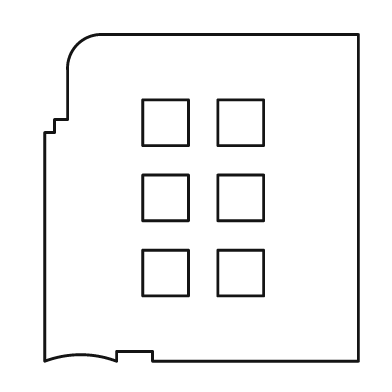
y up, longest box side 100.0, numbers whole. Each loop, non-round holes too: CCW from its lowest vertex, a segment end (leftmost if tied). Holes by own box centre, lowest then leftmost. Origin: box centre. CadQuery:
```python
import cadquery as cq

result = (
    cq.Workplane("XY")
    .moveTo(-48.0, -50.0)
    .threePointArc((-37.0, -48.0), (-26.0, -50.0))
    .lineTo(-26.0, -47.0)
    .lineTo(-15.0, -47.0)
    .lineTo(-15.0, -50.0)
    .lineTo(48.0, -50.0)
    .lineTo(48.0, 50.0)
    .lineTo(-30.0, 50.0)
    .threePointArc((-38.0, 47.0), (-41.0, 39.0))
    .lineTo(-41.0, 24.0)
    .lineTo(-45.0, 24.0)
    .lineTo(-45.0, 20.0)
    .lineTo(-48.0, 20.0)
    .close()
    .moveTo(-18.0, -30.0)
    .lineTo(-4.0, -30.0)
    .lineTo(-4.0, -16.0)
    .lineTo(-18.0, -16.0)
    .close()
    .moveTo(5.0, -30.0)
    .lineTo(19.0, -30.0)
    .lineTo(19.0, -16.0)
    .lineTo(5.0, -16.0)
    .close()
    .moveTo(-18.0, -7.0)
    .lineTo(-4.0, -7.0)
    .lineTo(-4.0, 7.0)
    .lineTo(-18.0, 7.0)
    .close()
    .moveTo(5.0, -7.0)
    .lineTo(19.0, -7.0)
    .lineTo(19.0, 7.0)
    .lineTo(5.0, 7.0)
    .close()
    .moveTo(-18.0, 16.0)
    .lineTo(-4.0, 16.0)
    .lineTo(-4.0, 30.0)
    .lineTo(-18.0, 30.0)
    .close()
    .moveTo(5.0, 16.0)
    .lineTo(19.0, 16.0)
    .lineTo(19.0, 30.0)
    .lineTo(5.0, 30.0)
    .close()
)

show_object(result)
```